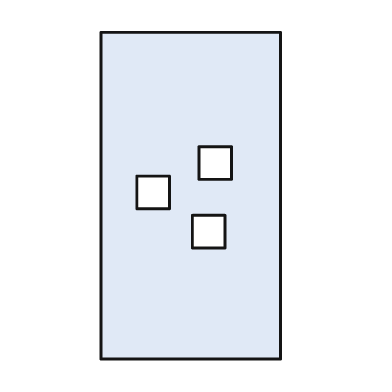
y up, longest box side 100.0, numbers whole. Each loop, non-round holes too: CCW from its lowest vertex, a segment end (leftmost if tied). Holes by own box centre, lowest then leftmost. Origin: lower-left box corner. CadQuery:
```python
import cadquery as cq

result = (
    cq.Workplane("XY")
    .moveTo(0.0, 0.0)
    .lineTo(55.0, 0.0)
    .lineTo(55.0, 100.0)
    .lineTo(0.0, 100.0)
    .close()
    .moveTo(28.0, 34.0)
    .lineTo(38.0, 34.0)
    .lineTo(38.0, 44.0)
    .lineTo(28.0, 44.0)
    .close()
    .moveTo(11.0, 46.0)
    .lineTo(21.0, 46.0)
    .lineTo(21.0, 56.0)
    .lineTo(11.0, 56.0)
    .close()
    .moveTo(30.0, 55.0)
    .lineTo(40.0, 55.0)
    .lineTo(40.0, 65.0)
    .lineTo(30.0, 65.0)
    .close()
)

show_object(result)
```